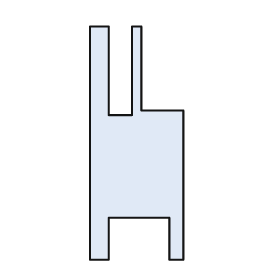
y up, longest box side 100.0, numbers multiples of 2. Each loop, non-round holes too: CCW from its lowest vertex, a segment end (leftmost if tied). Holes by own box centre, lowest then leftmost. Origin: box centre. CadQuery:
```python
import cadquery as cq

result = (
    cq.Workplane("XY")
    .moveTo(-20.0, -50.0)
    .lineTo(-12.0, -50.0)
    .lineTo(-12.0, -32.0)
    .lineTo(14.0, -32.0)
    .lineTo(14.0, -50.0)
    .lineTo(20.0, -50.0)
    .lineTo(20.0, 14.0)
    .lineTo(2.0, 14.0)
    .lineTo(2.0, 50.0)
    .lineTo(-2.0, 50.0)
    .lineTo(-2.0, 12.0)
    .lineTo(-12.0, 12.0)
    .lineTo(-12.0, 50.0)
    .lineTo(-20.0, 50.0)
    .close()
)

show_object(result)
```